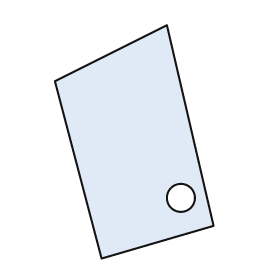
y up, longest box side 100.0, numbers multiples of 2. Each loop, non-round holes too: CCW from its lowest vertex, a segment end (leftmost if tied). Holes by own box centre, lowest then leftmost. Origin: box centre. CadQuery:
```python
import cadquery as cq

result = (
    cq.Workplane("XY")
    .moveTo(-14.0, -50.0)
    .lineTo(34.0, -36.0)
    .lineTo(14.0, 50.0)
    .lineTo(-34.0, 26.0)
    .close()
    .moveTo(20.0, -24.0)
    .circle(6.0)
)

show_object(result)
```